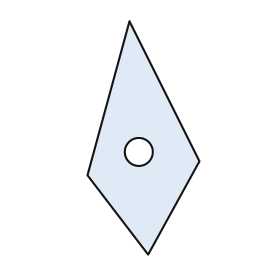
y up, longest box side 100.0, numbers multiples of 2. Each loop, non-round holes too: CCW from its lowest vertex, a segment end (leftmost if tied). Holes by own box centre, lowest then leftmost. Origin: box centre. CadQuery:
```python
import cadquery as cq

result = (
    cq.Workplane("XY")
    .moveTo(2.0, -50.0)
    .lineTo(24.0, -10.0)
    .lineTo(-6.0, 50.0)
    .lineTo(-24.0, -16.0)
    .close()
    .moveTo(-2.0, -6.0)
    .circle(6.0)
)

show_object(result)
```